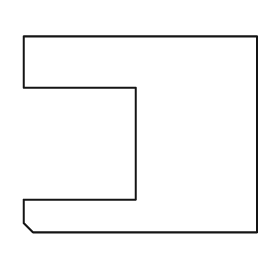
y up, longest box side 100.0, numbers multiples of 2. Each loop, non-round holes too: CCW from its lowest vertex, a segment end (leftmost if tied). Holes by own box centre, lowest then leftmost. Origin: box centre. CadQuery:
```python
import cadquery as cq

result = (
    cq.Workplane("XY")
    .moveTo(-46.0, -42.0)
    .lineTo(50.0, -42.0)
    .lineTo(50.0, 42.0)
    .lineTo(-50.0, 42.0)
    .lineTo(-50.0, 20.0)
    .lineTo(-2.0, 20.0)
    .lineTo(-2.0, -28.0)
    .lineTo(-50.0, -28.0)
    .lineTo(-50.0, -38.0)
    .close()
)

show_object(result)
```